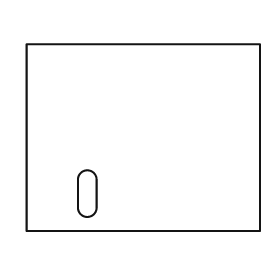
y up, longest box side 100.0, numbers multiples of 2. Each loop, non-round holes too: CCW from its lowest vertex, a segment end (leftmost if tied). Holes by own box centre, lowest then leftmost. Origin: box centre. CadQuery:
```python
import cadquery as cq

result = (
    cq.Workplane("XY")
    .moveTo(-50.0, -40.0)
    .lineTo(50.0, -40.0)
    .lineTo(50.0, 40.0)
    .lineTo(-50.0, 40.0)
    .close()
    .moveTo(-28.0, -30.0)
    .threePointArc((-24.0, -34.0), (-20.0, -30.0))
    .lineTo(-20.0, -18.0)
    .threePointArc((-24.0, -14.0), (-28.0, -18.0))
    .close()
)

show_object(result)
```